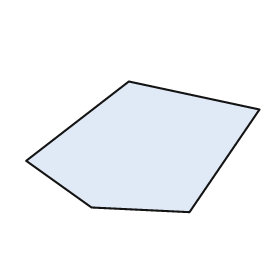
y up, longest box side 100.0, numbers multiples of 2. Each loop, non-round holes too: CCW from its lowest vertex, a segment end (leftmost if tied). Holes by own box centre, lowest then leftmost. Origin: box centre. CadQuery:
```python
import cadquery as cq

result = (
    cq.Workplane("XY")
    .moveTo(20.0, -28.0)
    .lineTo(50.0, 16.0)
    .lineTo(-6.0, 28.0)
    .lineTo(-50.0, -6.0)
    .lineTo(-22.0, -26.0)
    .close()
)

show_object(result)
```